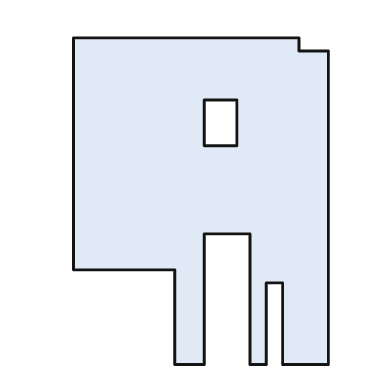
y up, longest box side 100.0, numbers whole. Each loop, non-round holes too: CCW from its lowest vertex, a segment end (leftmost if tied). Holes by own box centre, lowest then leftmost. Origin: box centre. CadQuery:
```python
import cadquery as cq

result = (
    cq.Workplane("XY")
    .moveTo(-8.0, -50.0)
    .lineTo(1.0, -50.0)
    .lineTo(1.0, -10.0)
    .lineTo(15.0, -10.0)
    .lineTo(15.0, -50.0)
    .lineTo(20.0, -50.0)
    .lineTo(20.0, -25.0)
    .lineTo(25.0, -25.0)
    .lineTo(25.0, -50.0)
    .lineTo(39.0, -50.0)
    .lineTo(39.0, 46.0)
    .lineTo(30.0, 46.0)
    .lineTo(30.0, 50.0)
    .lineTo(-39.0, 50.0)
    .lineTo(-39.0, -21.0)
    .lineTo(-8.0, -21.0)
    .close()
    .moveTo(1.0, 17.0)
    .lineTo(11.0, 17.0)
    .lineTo(11.0, 31.0)
    .lineTo(1.0, 31.0)
    .close()
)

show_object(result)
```